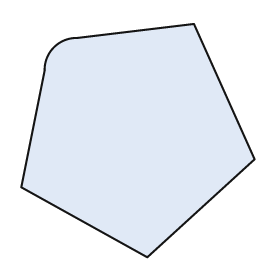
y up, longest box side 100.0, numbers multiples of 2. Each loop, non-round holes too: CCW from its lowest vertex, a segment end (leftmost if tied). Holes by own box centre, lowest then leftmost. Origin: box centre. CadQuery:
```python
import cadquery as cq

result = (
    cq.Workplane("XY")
    .moveTo(4.0, -50.0)
    .lineTo(50.0, -8.0)
    .lineTo(24.0, 50.0)
    .lineTo(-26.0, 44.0)
    .threePointArc((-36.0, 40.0), (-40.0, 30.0))
    .lineTo(-50.0, -20.0)
    .close()
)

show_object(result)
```